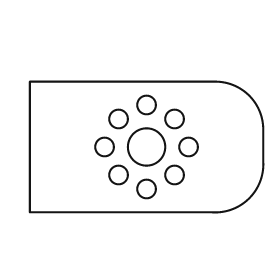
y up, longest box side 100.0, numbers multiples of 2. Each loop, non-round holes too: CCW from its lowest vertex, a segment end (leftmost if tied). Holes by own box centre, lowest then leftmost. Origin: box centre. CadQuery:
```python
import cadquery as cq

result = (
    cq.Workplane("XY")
    .moveTo(-50.0, -28.0)
    .lineTo(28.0, -28.0)
    .threePointArc((44.0, -22.0), (50.0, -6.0))
    .lineTo(50.0, 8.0)
    .threePointArc((44.0, 22.0), (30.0, 28.0))
    .lineTo(-50.0, 28.0)
    .close()
    .moveTo(0.0, -18.0)
    .circle(4.0)
    .moveTo(-12.0, -12.0)
    .circle(4.0)
    .moveTo(12.0, -12.0)
    .circle(4.0)
    .moveTo(-18.0, 0.0)
    .circle(4.0)
    .moveTo(0.0, 0.0)
    .circle(8.0)
    .moveTo(18.0, 0.0)
    .circle(4.0)
    .moveTo(-12.0, 12.0)
    .circle(4.0)
    .moveTo(12.0, 12.0)
    .circle(4.0)
    .moveTo(0.0, 18.0)
    .circle(4.0)
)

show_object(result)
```